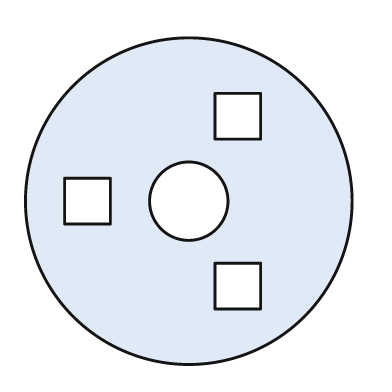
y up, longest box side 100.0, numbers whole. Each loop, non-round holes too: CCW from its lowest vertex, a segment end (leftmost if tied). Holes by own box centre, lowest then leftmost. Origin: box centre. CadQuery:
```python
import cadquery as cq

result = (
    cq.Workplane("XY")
    .moveTo(0.0, 0.0)
    .circle(50.0)
    .moveTo(8.0, -33.0)
    .lineTo(22.0, -33.0)
    .lineTo(22.0, -19.0)
    .lineTo(8.0, -19.0)
    .close()
    .moveTo(-38.0, -7.0)
    .lineTo(-24.0, -7.0)
    .lineTo(-24.0, 7.0)
    .lineTo(-38.0, 7.0)
    .close()
    .moveTo(0.0, 0.0)
    .circle(12.0)
    .moveTo(8.0, 19.0)
    .lineTo(22.0, 19.0)
    .lineTo(22.0, 33.0)
    .lineTo(8.0, 33.0)
    .close()
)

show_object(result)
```